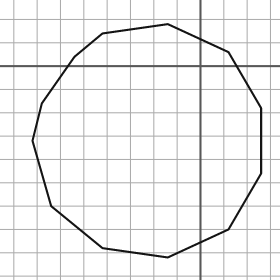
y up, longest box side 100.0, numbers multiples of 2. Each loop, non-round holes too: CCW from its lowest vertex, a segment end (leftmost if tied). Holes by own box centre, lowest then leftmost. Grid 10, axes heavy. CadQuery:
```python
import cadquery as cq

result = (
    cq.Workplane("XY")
    .moveTo(-14.0, -82.0)
    .lineTo(12.0, -70.0)
    .lineTo(26.0, -46.0)
    .lineTo(26.0, -18.0)
    .lineTo(12.0, 6.0)
    .lineTo(-14.0, 18.0)
    .lineTo(-42.0, 14.0)
    .lineTo(-54.0, 4.0)
    .lineTo(-68.0, -16.0)
    .lineTo(-72.0, -32.0)
    .lineTo(-64.0, -60.0)
    .lineTo(-42.0, -78.0)
    .close()
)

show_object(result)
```